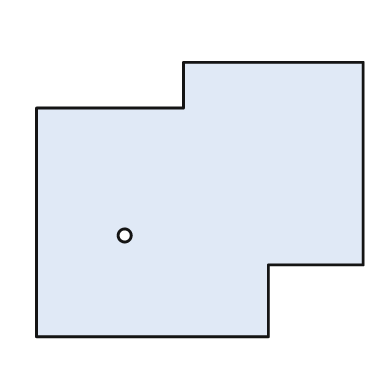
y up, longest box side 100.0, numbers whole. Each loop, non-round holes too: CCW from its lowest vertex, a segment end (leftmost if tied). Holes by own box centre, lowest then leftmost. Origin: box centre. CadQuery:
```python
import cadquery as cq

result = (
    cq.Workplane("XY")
    .moveTo(-50.0, -42.0)
    .lineTo(21.0, -42.0)
    .lineTo(21.0, -20.0)
    .lineTo(50.0, -20.0)
    .lineTo(50.0, 42.0)
    .lineTo(-5.0, 42.0)
    .lineTo(-5.0, 28.0)
    .lineTo(-50.0, 28.0)
    .close()
    .moveTo(-23.0, -11.0)
    .circle(2.0)
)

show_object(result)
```